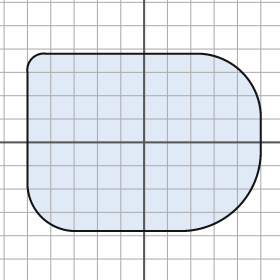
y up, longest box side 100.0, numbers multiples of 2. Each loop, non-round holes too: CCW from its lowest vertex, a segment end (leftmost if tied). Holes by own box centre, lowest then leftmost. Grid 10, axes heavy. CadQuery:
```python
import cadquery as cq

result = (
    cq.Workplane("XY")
    .moveTo(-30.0, -38.0)
    .lineTo(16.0, -38.0)
    .threePointArc((40.0, -28.0), (50.0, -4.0))
    .lineTo(50.0, 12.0)
    .threePointArc((42.0, 30.0), (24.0, 38.0))
    .lineTo(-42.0, 38.0)
    .threePointArc((-48.0, 36.0), (-50.0, 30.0))
    .lineTo(-50.0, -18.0)
    .threePointArc((-44.0, -32.0), (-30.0, -38.0))
    .close()
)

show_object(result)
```